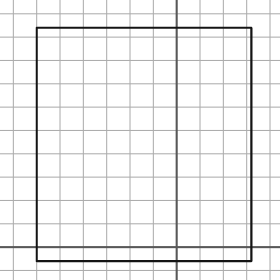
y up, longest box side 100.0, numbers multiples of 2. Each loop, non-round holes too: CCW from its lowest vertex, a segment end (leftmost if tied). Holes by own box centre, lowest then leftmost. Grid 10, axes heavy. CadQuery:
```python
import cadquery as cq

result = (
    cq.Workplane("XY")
    .moveTo(-60.0, -6.0)
    .lineTo(32.0, -6.0)
    .lineTo(32.0, 94.0)
    .lineTo(-60.0, 94.0)
    .close()
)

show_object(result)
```